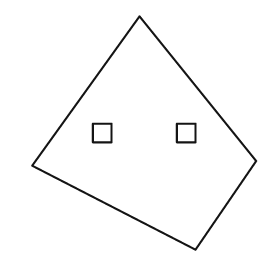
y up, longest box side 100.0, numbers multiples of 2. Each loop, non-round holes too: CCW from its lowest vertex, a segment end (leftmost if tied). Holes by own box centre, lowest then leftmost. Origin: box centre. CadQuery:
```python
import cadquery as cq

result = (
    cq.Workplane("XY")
    .moveTo(22.0, -50.0)
    .lineTo(48.0, -12.0)
    .lineTo(-2.0, 50.0)
    .lineTo(-48.0, -14.0)
    .close()
    .moveTo(-22.0, -4.0)
    .lineTo(-14.0, -4.0)
    .lineTo(-14.0, 4.0)
    .lineTo(-22.0, 4.0)
    .close()
    .moveTo(14.0, -4.0)
    .lineTo(22.0, -4.0)
    .lineTo(22.0, 4.0)
    .lineTo(14.0, 4.0)
    .close()
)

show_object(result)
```